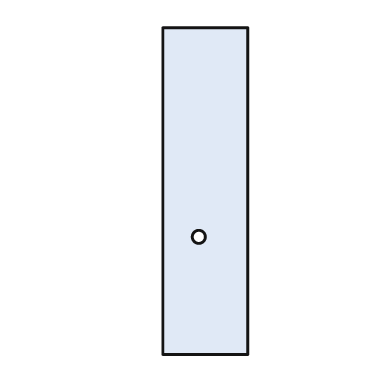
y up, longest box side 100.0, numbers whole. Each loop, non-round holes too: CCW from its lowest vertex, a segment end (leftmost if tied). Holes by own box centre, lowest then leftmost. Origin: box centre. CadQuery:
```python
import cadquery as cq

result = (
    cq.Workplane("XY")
    .moveTo(-13.0, -50.0)
    .lineTo(13.0, -50.0)
    .lineTo(13.0, 50.0)
    .lineTo(-13.0, 50.0)
    .close()
    .moveTo(-2.0, -14.0)
    .circle(2.0)
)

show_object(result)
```